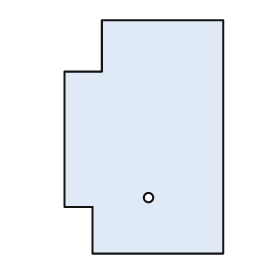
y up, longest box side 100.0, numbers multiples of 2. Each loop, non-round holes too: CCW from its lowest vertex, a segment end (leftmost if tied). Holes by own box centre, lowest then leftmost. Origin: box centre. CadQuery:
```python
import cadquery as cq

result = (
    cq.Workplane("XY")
    .moveTo(-22.0, -50.0)
    .lineTo(34.0, -50.0)
    .lineTo(34.0, 50.0)
    .lineTo(-18.0, 50.0)
    .lineTo(-18.0, 28.0)
    .lineTo(-34.0, 28.0)
    .lineTo(-34.0, -30.0)
    .lineTo(-22.0, -30.0)
    .close()
    .moveTo(2.0, -26.0)
    .circle(2.0)
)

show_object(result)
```